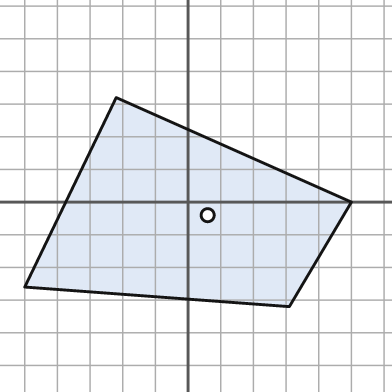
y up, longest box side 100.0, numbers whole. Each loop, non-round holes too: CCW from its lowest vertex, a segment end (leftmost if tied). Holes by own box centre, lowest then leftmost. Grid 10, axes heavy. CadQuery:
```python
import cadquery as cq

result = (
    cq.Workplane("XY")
    .moveTo(31.0, -32.0)
    .lineTo(50.0, 0.0)
    .lineTo(-22.0, 32.0)
    .lineTo(-50.0, -26.0)
    .close()
    .moveTo(6.0, -4.0)
    .circle(2.0)
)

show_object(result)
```